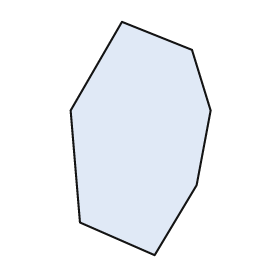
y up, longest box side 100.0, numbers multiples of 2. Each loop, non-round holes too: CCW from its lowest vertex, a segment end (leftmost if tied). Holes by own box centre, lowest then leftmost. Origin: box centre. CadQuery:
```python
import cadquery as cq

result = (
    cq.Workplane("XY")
    .moveTo(6.0, -50.0)
    .lineTo(24.0, -20.0)
    .lineTo(30.0, 12.0)
    .lineTo(22.0, 38.0)
    .lineTo(-8.0, 50.0)
    .lineTo(-30.0, 12.0)
    .lineTo(-26.0, -36.0)
    .close()
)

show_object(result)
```